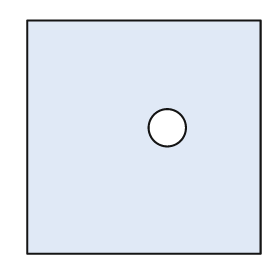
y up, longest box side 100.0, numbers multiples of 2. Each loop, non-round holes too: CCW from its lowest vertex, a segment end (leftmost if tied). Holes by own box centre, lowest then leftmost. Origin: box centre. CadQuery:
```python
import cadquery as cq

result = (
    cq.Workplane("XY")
    .moveTo(-50.0, -50.0)
    .lineTo(50.0, -50.0)
    .lineTo(50.0, 50.0)
    .lineTo(-50.0, 50.0)
    .close()
    .moveTo(10.0, 4.0)
    .circle(8.0)
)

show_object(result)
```